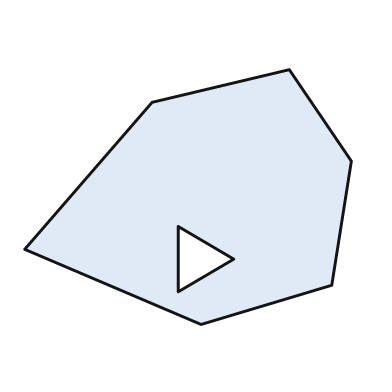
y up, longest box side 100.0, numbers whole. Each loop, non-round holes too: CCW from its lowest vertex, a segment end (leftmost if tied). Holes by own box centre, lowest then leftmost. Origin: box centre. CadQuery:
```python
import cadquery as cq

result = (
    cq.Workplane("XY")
    .moveTo(4.0, -39.0)
    .lineTo(44.0, -27.0)
    .lineTo(50.0, 11.0)
    .lineTo(31.0, 39.0)
    .lineTo(-11.0, 29.0)
    .lineTo(-50.0, -16.0)
    .close()
    .moveTo(-3.0, -29.0)
    .lineTo(14.0, -19.0)
    .lineTo(-3.0, -9.0)
    .close()
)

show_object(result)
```